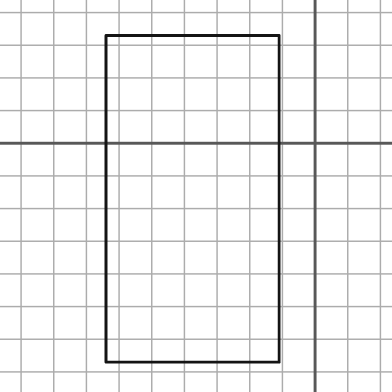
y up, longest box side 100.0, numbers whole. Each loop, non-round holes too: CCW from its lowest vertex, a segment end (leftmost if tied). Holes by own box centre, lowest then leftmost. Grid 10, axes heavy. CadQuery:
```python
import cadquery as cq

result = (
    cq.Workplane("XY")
    .moveTo(-64.0, -67.0)
    .lineTo(-11.0, -67.0)
    .lineTo(-11.0, 33.0)
    .lineTo(-64.0, 33.0)
    .close()
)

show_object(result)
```